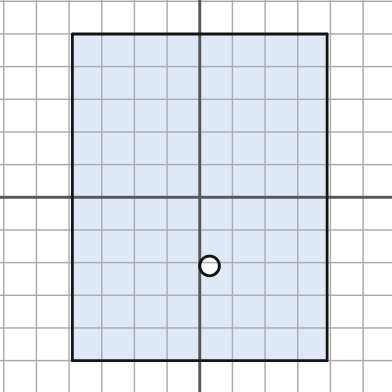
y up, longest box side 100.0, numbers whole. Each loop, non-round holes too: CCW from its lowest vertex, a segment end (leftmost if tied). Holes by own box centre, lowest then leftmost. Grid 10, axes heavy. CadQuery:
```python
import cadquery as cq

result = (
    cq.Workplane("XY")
    .moveTo(-39.0, -50.0)
    .lineTo(39.0, -50.0)
    .lineTo(39.0, 50.0)
    .lineTo(-39.0, 50.0)
    .close()
    .moveTo(3.0, -21.0)
    .circle(3.0)
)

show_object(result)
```